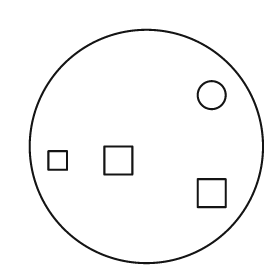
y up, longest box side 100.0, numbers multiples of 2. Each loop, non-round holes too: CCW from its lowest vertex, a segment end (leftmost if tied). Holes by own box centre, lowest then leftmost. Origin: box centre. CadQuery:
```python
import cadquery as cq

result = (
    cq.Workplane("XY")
    .moveTo(0.0, 0.0)
    .circle(50.0)
    .moveTo(22.0, -26.0)
    .lineTo(34.0, -26.0)
    .lineTo(34.0, -14.0)
    .lineTo(22.0, -14.0)
    .close()
    .moveTo(-42.0, -10.0)
    .lineTo(-34.0, -10.0)
    .lineTo(-34.0, -2.0)
    .lineTo(-42.0, -2.0)
    .close()
    .moveTo(-18.0, -12.0)
    .lineTo(-6.0, -12.0)
    .lineTo(-6.0, 0.0)
    .lineTo(-18.0, 0.0)
    .close()
    .moveTo(28.0, 22.0)
    .circle(6.0)
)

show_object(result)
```